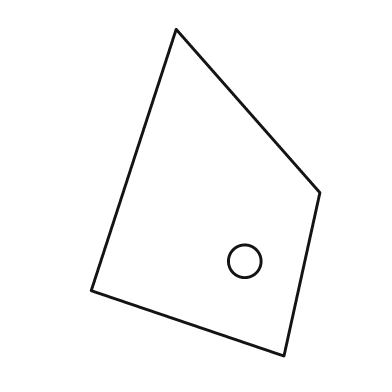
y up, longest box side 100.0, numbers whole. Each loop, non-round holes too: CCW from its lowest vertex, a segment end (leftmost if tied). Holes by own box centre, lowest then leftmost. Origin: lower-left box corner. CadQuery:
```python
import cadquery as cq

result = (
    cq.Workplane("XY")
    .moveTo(59.0, 0.0)
    .lineTo(70.0, 50.0)
    .lineTo(26.0, 100.0)
    .lineTo(0.0, 20.0)
    .close()
    .moveTo(47.0, 29.0)
    .circle(5.0)
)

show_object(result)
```